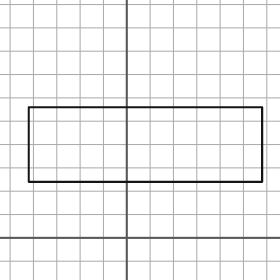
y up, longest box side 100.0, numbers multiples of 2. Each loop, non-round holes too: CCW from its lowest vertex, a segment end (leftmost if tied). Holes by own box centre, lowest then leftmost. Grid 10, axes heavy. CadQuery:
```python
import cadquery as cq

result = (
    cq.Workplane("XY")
    .moveTo(-42.0, 24.0)
    .lineTo(58.0, 24.0)
    .lineTo(58.0, 56.0)
    .lineTo(-42.0, 56.0)
    .close()
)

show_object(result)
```